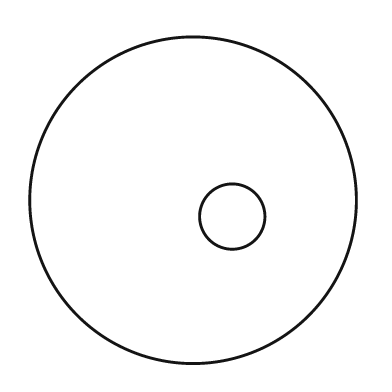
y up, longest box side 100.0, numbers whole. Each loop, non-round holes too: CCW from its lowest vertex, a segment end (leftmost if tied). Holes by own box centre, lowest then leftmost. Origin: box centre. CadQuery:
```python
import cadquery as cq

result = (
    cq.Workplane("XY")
    .moveTo(0.0, 0.0)
    .circle(50.0)
    .moveTo(12.0, -5.0)
    .circle(10.0)
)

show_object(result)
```